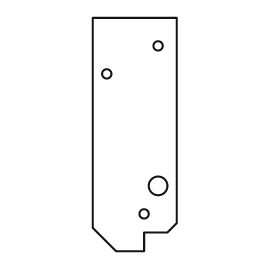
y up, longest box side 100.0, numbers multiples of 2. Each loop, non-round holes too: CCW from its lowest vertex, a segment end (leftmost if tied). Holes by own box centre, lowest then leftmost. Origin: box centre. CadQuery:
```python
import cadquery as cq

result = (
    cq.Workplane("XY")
    .moveTo(-8.0, -50.0)
    .lineTo(4.0, -50.0)
    .lineTo(4.0, -42.0)
    .lineTo(14.0, -42.0)
    .lineTo(18.0, -38.0)
    .lineTo(18.0, 50.0)
    .lineTo(-18.0, 50.0)
    .lineTo(-18.0, -40.0)
    .close()
    .moveTo(4.0, -34.0)
    .circle(2.0)
    .moveTo(10.0, -22.0)
    .circle(4.0)
    .moveTo(-12.0, 26.0)
    .circle(2.0)
    .moveTo(10.0, 38.0)
    .circle(2.0)
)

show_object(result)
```